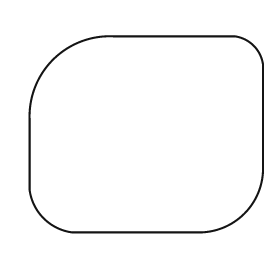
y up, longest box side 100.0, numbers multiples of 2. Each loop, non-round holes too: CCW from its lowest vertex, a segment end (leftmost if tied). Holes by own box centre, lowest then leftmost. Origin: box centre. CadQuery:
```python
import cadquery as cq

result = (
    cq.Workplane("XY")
    .moveTo(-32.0, -42.0)
    .lineTo(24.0, -42.0)
    .threePointArc((42.0, -34.0), (50.0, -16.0))
    .lineTo(50.0, 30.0)
    .threePointArc((46.0, 38.0), (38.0, 42.0))
    .lineTo(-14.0, 42.0)
    .threePointArc((-40.0, 32.0), (-50.0, 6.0))
    .lineTo(-50.0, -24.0)
    .threePointArc((-44.0, -36.0), (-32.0, -42.0))
    .close()
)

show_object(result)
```